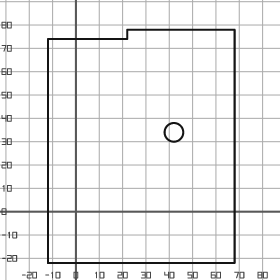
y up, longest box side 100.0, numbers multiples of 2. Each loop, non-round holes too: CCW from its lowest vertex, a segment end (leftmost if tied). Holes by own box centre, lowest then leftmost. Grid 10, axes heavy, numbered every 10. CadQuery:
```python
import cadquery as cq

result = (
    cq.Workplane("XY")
    .moveTo(-12.0, -22.0)
    .lineTo(68.0, -22.0)
    .lineTo(68.0, 78.0)
    .lineTo(22.0, 78.0)
    .lineTo(22.0, 74.0)
    .lineTo(-12.0, 74.0)
    .close()
    .moveTo(42.0, 34.0)
    .circle(4.0)
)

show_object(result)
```